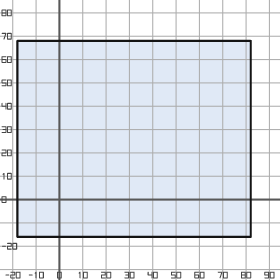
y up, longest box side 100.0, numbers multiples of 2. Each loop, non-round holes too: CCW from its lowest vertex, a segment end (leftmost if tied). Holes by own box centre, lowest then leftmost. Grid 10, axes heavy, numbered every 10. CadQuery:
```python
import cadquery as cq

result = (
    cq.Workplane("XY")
    .moveTo(-18.0, -16.0)
    .lineTo(82.0, -16.0)
    .lineTo(82.0, 68.0)
    .lineTo(-18.0, 68.0)
    .close()
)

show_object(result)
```